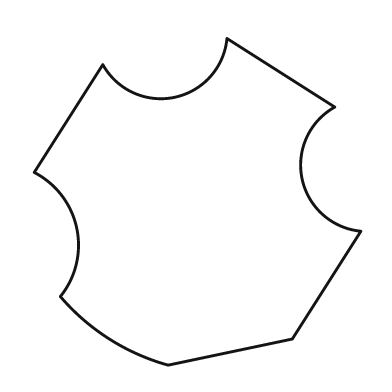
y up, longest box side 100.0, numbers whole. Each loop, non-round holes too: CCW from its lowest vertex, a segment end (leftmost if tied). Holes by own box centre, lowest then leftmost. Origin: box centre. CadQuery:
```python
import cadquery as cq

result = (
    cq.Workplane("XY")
    .moveTo(-9.0, -50.0)
    .lineTo(29.0, -42.0)
    .lineTo(50.0, -9.0)
    .threePointArc((32.0, 7.0), (42.0, 29.0))
    .lineTo(9.0, 50.0)
    .threePointArc((-7.0, 32.0), (-29.0, 42.0))
    .lineTo(-50.0, 9.0)
    .threePointArc((-37.0, -8.0), (-42.0, -29.0))
    .threePointArc((-27.0, -42.0), (-9.0, -50.0))
    .close()
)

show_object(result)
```